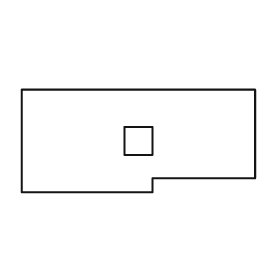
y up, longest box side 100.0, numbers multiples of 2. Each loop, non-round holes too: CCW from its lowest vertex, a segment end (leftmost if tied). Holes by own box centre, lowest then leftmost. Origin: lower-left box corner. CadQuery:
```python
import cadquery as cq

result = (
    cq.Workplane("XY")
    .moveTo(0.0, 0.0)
    .lineTo(56.0, 0.0)
    .lineTo(56.0, 6.0)
    .lineTo(100.0, 6.0)
    .lineTo(100.0, 44.0)
    .lineTo(0.0, 44.0)
    .close()
    .moveTo(44.0, 16.0)
    .lineTo(56.0, 16.0)
    .lineTo(56.0, 28.0)
    .lineTo(44.0, 28.0)
    .close()
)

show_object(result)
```